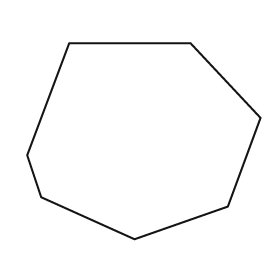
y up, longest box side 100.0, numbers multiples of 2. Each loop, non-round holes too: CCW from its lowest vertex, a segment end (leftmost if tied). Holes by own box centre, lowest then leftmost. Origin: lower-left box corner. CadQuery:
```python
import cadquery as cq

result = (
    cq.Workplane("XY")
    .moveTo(46.0, 0.0)
    .lineTo(86.0, 14.0)
    .lineTo(100.0, 52.0)
    .lineTo(70.0, 84.0)
    .lineTo(18.0, 84.0)
    .lineTo(0.0, 36.0)
    .lineTo(6.0, 18.0)
    .close()
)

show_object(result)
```